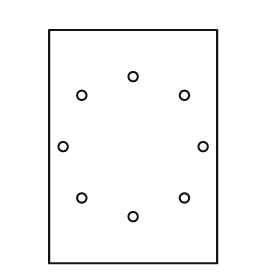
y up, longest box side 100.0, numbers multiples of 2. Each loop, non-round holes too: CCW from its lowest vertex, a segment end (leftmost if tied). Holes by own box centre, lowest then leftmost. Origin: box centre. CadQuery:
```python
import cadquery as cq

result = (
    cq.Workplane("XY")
    .moveTo(-36.0, -50.0)
    .lineTo(36.0, -50.0)
    .lineTo(36.0, 50.0)
    .lineTo(-36.0, 50.0)
    .close()
    .moveTo(0.0, -30.0)
    .circle(2.0)
    .moveTo(-22.0, -22.0)
    .circle(2.0)
    .moveTo(22.0, -22.0)
    .circle(2.0)
    .moveTo(-30.0, 0.0)
    .circle(2.0)
    .moveTo(30.0, 0.0)
    .circle(2.0)
    .moveTo(-22.0, 22.0)
    .circle(2.0)
    .moveTo(22.0, 22.0)
    .circle(2.0)
    .moveTo(0.0, 30.0)
    .circle(2.0)
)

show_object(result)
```